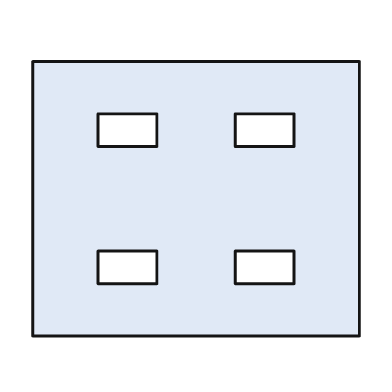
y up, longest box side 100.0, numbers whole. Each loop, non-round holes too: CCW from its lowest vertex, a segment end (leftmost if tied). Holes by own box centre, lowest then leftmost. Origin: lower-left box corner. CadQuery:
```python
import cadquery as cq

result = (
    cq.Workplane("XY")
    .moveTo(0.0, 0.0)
    .lineTo(100.0, 0.0)
    .lineTo(100.0, 84.0)
    .lineTo(0.0, 84.0)
    .close()
    .moveTo(20.0, 16.0)
    .lineTo(38.0, 16.0)
    .lineTo(38.0, 26.0)
    .lineTo(20.0, 26.0)
    .close()
    .moveTo(62.0, 16.0)
    .lineTo(80.0, 16.0)
    .lineTo(80.0, 26.0)
    .lineTo(62.0, 26.0)
    .close()
    .moveTo(20.0, 58.0)
    .lineTo(38.0, 58.0)
    .lineTo(38.0, 68.0)
    .lineTo(20.0, 68.0)
    .close()
    .moveTo(62.0, 58.0)
    .lineTo(80.0, 58.0)
    .lineTo(80.0, 68.0)
    .lineTo(62.0, 68.0)
    .close()
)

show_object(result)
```